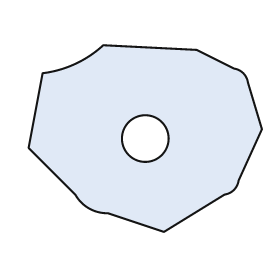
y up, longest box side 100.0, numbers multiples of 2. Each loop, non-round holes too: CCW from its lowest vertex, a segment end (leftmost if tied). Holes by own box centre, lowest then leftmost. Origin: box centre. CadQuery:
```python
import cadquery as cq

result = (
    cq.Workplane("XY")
    .moveTo(8.0, -40.0)
    .lineTo(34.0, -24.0)
    .threePointArc((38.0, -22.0), (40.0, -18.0))
    .lineTo(50.0, 4.0)
    .lineTo(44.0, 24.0)
    .threePointArc((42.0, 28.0), (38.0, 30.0))
    .lineTo(22.0, 38.0)
    .lineTo(-18.0, 40.0)
    .threePointArc((-30.0, 32.0), (-44.0, 28.0))
    .lineTo(-50.0, -4.0)
    .lineTo(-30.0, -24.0)
    .threePointArc((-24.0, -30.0), (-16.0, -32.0))
    .close()
    .moveTo(0.0, 0.0)
    .circle(10.0)
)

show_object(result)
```